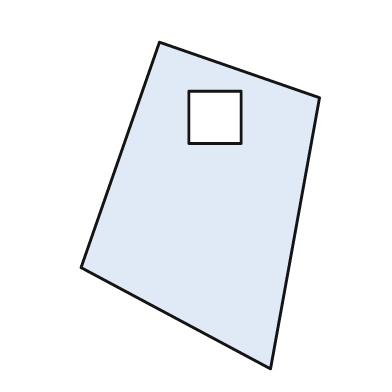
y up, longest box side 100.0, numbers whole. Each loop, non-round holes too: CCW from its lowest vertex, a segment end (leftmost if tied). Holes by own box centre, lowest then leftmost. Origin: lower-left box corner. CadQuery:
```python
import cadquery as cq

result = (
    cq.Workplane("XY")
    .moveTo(58.0, 0.0)
    .lineTo(73.0, 83.0)
    .lineTo(24.0, 100.0)
    .lineTo(0.0, 31.0)
    .close()
    .moveTo(33.0, 69.0)
    .lineTo(49.0, 69.0)
    .lineTo(49.0, 85.0)
    .lineTo(33.0, 85.0)
    .close()
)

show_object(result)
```